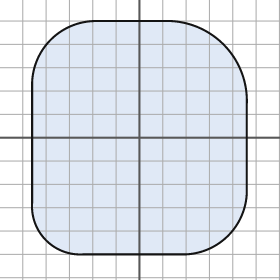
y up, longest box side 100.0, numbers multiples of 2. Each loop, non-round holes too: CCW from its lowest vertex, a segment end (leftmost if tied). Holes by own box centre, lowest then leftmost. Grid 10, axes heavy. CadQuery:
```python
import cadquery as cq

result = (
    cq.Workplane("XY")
    .moveTo(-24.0, -50.0)
    .lineTo(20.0, -50.0)
    .threePointArc((38.0, -42.0), (46.0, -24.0))
    .lineTo(46.0, 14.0)
    .threePointArc((36.0, 40.0), (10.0, 50.0))
    .lineTo(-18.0, 50.0)
    .threePointArc((-38.0, 42.0), (-46.0, 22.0))
    .lineTo(-46.0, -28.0)
    .threePointArc((-40.0, -44.0), (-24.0, -50.0))
    .close()
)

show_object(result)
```